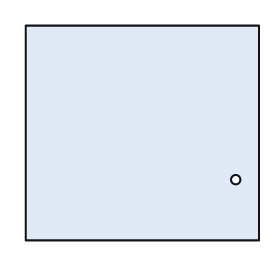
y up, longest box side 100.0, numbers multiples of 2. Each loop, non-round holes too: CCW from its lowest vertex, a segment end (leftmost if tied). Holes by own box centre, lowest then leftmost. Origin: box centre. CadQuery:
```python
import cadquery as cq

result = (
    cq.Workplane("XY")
    .moveTo(-50.0, -46.0)
    .lineTo(50.0, -46.0)
    .lineTo(50.0, 46.0)
    .lineTo(-50.0, 46.0)
    .close()
    .moveTo(40.0, -20.0)
    .circle(2.0)
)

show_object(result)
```